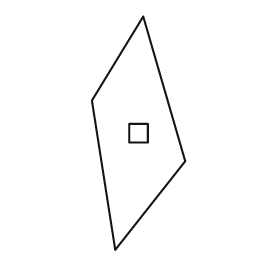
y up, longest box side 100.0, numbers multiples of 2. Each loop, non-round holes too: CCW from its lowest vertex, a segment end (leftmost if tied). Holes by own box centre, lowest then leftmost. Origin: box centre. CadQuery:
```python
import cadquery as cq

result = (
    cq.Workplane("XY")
    .moveTo(-10.0, -50.0)
    .lineTo(20.0, -12.0)
    .lineTo(2.0, 50.0)
    .lineTo(-20.0, 14.0)
    .close()
    .moveTo(-4.0, -4.0)
    .lineTo(4.0, -4.0)
    .lineTo(4.0, 4.0)
    .lineTo(-4.0, 4.0)
    .close()
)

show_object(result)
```